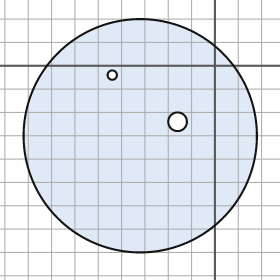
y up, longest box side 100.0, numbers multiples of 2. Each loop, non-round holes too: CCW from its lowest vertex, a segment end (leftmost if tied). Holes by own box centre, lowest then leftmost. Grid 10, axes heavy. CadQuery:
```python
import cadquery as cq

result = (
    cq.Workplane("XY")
    .moveTo(-32.0, -30.0)
    .circle(50.0)
    .moveTo(-16.0, -24.0)
    .circle(4.0)
    .moveTo(-44.0, -4.0)
    .circle(2.0)
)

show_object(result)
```